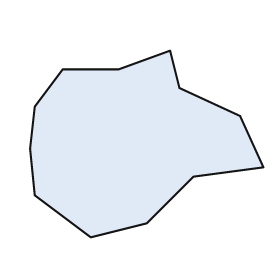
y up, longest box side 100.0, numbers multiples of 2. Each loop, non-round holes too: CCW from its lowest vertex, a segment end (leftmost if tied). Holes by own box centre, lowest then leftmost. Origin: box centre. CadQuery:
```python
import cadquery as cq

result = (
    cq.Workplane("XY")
    .moveTo(-24.0, -40.0)
    .lineTo(0.0, -34.0)
    .lineTo(20.0, -14.0)
    .lineTo(50.0, -10.0)
    .lineTo(40.0, 12.0)
    .lineTo(14.0, 24.0)
    .lineTo(10.0, 40.0)
    .lineTo(-12.0, 32.0)
    .lineTo(-36.0, 32.0)
    .lineTo(-48.0, 16.0)
    .lineTo(-50.0, -2.0)
    .lineTo(-48.0, -22.0)
    .close()
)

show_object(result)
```